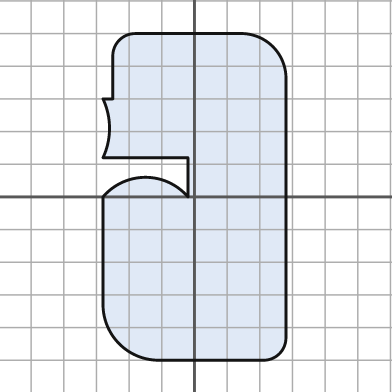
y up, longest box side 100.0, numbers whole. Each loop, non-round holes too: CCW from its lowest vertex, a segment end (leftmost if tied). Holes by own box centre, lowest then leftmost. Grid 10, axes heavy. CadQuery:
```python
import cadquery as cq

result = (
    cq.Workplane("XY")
    .moveTo(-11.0, -50.0)
    .lineTo(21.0, -50.0)
    .threePointArc((26.0, -48.0), (28.0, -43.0))
    .lineTo(28.0, 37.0)
    .threePointArc((24.0, 46.0), (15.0, 50.0))
    .lineTo(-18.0, 50.0)
    .threePointArc((-23.0, 48.0), (-25.0, 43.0))
    .lineTo(-25.0, 30.0)
    .lineTo(-28.0, 30.0)
    .threePointArc((-26.0, 21.0), (-28.0, 12.0))
    .lineTo(-2.0, 12.0)
    .lineTo(-2.0, 0.0)
    .threePointArc((-15.0, 6.0), (-28.0, 0.0))
    .lineTo(-28.0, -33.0)
    .threePointArc((-23.0, -45.0), (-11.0, -50.0))
    .close()
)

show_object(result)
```